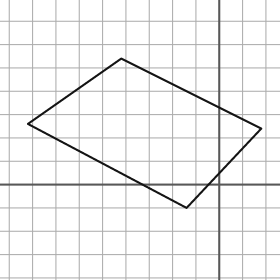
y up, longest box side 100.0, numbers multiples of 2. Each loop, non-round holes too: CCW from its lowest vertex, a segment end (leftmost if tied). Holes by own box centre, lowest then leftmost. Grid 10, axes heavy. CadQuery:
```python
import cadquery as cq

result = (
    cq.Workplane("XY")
    .moveTo(-14.0, -10.0)
    .lineTo(18.0, 24.0)
    .lineTo(-42.0, 54.0)
    .lineTo(-82.0, 26.0)
    .close()
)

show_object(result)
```